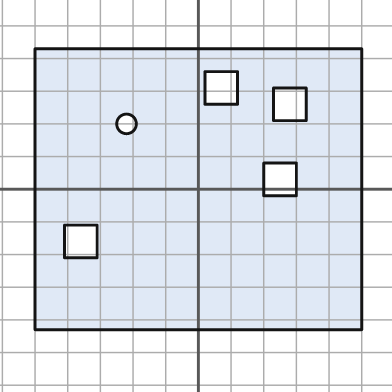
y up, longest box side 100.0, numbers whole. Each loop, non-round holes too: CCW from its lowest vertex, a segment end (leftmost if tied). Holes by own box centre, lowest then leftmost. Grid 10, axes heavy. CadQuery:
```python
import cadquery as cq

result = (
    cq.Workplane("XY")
    .moveTo(-50.0, -43.0)
    .lineTo(50.0, -43.0)
    .lineTo(50.0, 43.0)
    .lineTo(-50.0, 43.0)
    .close()
    .moveTo(-41.0, -21.0)
    .lineTo(-31.0, -21.0)
    .lineTo(-31.0, -11.0)
    .lineTo(-41.0, -11.0)
    .close()
    .moveTo(20.0, -2.0)
    .lineTo(30.0, -2.0)
    .lineTo(30.0, 8.0)
    .lineTo(20.0, 8.0)
    .close()
    .moveTo(-22.0, 20.0)
    .circle(3.0)
    .moveTo(23.0, 21.0)
    .lineTo(33.0, 21.0)
    .lineTo(33.0, 31.0)
    .lineTo(23.0, 31.0)
    .close()
    .moveTo(2.0, 26.0)
    .lineTo(12.0, 26.0)
    .lineTo(12.0, 36.0)
    .lineTo(2.0, 36.0)
    .close()
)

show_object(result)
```